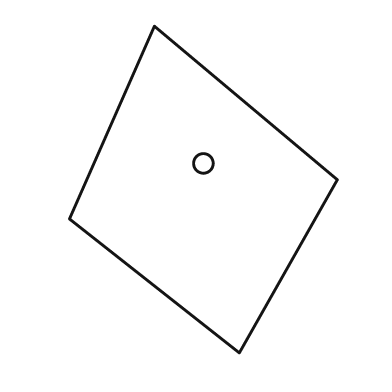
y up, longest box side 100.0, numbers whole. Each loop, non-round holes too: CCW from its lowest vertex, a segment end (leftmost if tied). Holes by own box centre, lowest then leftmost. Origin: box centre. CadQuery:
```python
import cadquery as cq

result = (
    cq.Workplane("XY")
    .moveTo(11.0, -50.0)
    .lineTo(41.0, 3.0)
    .lineTo(-15.0, 50.0)
    .lineTo(-41.0, -9.0)
    .close()
    .moveTo(0.0, 8.0)
    .circle(3.0)
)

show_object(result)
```